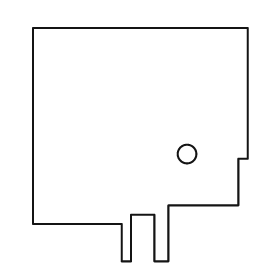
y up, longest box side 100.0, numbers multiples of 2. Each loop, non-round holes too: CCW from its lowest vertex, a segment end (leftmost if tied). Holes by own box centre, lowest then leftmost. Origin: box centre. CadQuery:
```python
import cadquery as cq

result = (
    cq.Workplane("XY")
    .moveTo(-8.0, -50.0)
    .lineTo(-4.0, -50.0)
    .lineTo(-4.0, -30.0)
    .lineTo(6.0, -30.0)
    .lineTo(6.0, -50.0)
    .lineTo(12.0, -50.0)
    .lineTo(12.0, -26.0)
    .lineTo(42.0, -26.0)
    .lineTo(42.0, -6.0)
    .lineTo(46.0, -6.0)
    .lineTo(46.0, 50.0)
    .lineTo(-46.0, 50.0)
    .lineTo(-46.0, -34.0)
    .lineTo(-8.0, -34.0)
    .close()
    .moveTo(20.0, -4.0)
    .circle(4.0)
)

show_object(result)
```